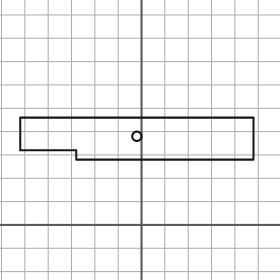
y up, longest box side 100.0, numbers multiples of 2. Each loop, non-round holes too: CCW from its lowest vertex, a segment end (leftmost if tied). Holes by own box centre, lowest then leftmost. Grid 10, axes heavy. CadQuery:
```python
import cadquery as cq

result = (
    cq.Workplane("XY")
    .moveTo(-28.0, 28.0)
    .lineTo(48.0, 28.0)
    .lineTo(48.0, 46.0)
    .lineTo(-52.0, 46.0)
    .lineTo(-52.0, 32.0)
    .lineTo(-28.0, 32.0)
    .close()
    .moveTo(-2.0, 38.0)
    .circle(2.0)
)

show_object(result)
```